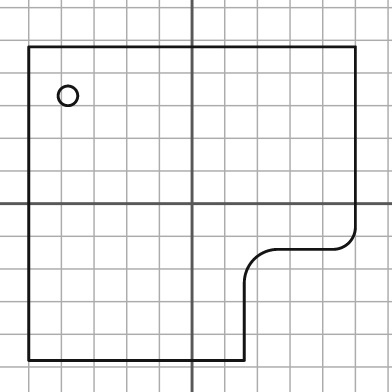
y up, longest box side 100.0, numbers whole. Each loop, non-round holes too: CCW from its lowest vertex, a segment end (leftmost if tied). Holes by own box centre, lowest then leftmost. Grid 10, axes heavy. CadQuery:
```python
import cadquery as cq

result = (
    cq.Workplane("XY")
    .moveTo(-50.0, -48.0)
    .lineTo(16.0, -48.0)
    .lineTo(16.0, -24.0)
    .threePointArc((19.0, -17.0), (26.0, -14.0))
    .lineTo(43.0, -14.0)
    .threePointArc((48.0, -12.0), (50.0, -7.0))
    .lineTo(50.0, 48.0)
    .lineTo(-50.0, 48.0)
    .close()
    .moveTo(-38.0, 33.0)
    .circle(3.0)
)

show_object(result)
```